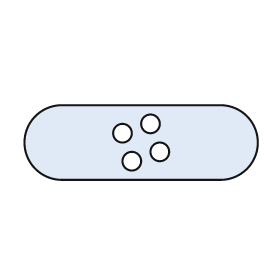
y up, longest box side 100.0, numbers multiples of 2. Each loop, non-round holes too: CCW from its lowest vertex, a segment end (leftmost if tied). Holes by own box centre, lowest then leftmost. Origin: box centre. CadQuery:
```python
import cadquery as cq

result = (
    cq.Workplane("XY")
    .moveTo(-34.0, -16.0)
    .lineTo(34.0, -16.0)
    .threePointArc((50.0, 0.0), (34.0, 16.0))
    .lineTo(-34.0, 16.0)
    .threePointArc((-50.0, 0.0), (-34.0, -16.0))
    .close()
    .moveTo(-4.0, -8.0)
    .circle(4.0)
    .moveTo(8.0, -4.0)
    .circle(4.0)
    .moveTo(-8.0, 4.0)
    .circle(4.0)
    .moveTo(4.0, 8.0)
    .circle(4.0)
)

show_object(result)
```